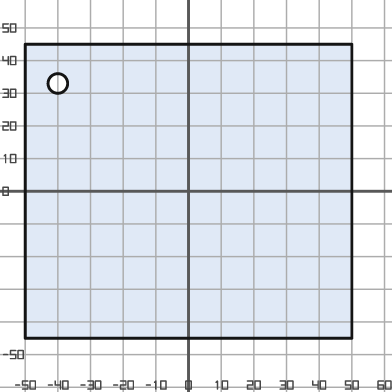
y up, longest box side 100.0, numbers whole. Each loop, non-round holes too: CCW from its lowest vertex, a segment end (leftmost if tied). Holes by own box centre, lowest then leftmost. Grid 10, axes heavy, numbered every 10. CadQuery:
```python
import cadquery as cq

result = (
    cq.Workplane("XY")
    .moveTo(-50.0, -45.0)
    .lineTo(50.0, -45.0)
    .lineTo(50.0, 45.0)
    .lineTo(-50.0, 45.0)
    .close()
    .moveTo(-40.0, 33.0)
    .circle(3.0)
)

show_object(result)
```